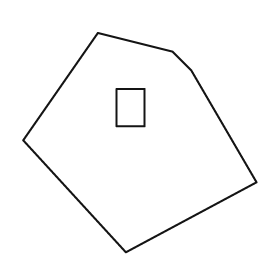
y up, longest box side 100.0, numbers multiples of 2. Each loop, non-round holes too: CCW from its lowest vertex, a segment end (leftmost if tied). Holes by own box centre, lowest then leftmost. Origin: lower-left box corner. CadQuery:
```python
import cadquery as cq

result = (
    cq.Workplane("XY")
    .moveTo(44.0, 0.0)
    .lineTo(100.0, 30.0)
    .lineTo(72.0, 78.0)
    .lineTo(64.0, 86.0)
    .lineTo(32.0, 94.0)
    .lineTo(0.0, 48.0)
    .close()
    .moveTo(40.0, 54.0)
    .lineTo(52.0, 54.0)
    .lineTo(52.0, 70.0)
    .lineTo(40.0, 70.0)
    .close()
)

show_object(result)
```